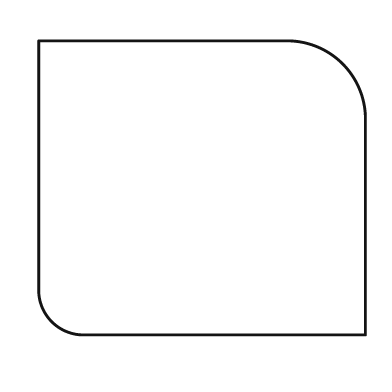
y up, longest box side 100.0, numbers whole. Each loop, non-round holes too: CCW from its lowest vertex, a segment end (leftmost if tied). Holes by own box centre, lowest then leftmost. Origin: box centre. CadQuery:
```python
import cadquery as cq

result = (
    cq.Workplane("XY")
    .moveTo(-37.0, -45.0)
    .lineTo(50.0, -45.0)
    .lineTo(50.0, 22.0)
    .threePointArc((43.0, 38.0), (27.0, 45.0))
    .lineTo(-50.0, 45.0)
    .lineTo(-50.0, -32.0)
    .threePointArc((-46.0, -41.0), (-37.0, -45.0))
    .close()
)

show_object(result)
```